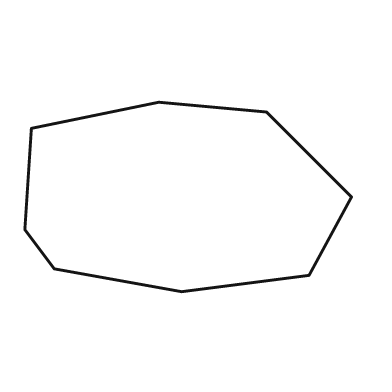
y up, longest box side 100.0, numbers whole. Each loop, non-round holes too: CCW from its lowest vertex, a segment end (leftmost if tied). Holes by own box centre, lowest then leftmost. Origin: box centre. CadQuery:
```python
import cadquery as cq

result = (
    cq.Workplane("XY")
    .moveTo(-2.0, -29.0)
    .lineTo(37.0, -24.0)
    .lineTo(50.0, 0.0)
    .lineTo(24.0, 26.0)
    .lineTo(-9.0, 29.0)
    .lineTo(-48.0, 21.0)
    .lineTo(-50.0, -10.0)
    .lineTo(-41.0, -22.0)
    .close()
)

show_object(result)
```